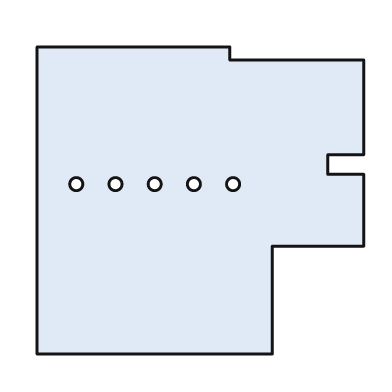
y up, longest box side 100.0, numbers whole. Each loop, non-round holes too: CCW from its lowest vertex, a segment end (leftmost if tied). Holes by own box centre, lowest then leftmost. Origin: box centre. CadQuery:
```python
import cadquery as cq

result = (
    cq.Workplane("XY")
    .moveTo(-50.0, -47.0)
    .lineTo(22.0, -47.0)
    .lineTo(22.0, -14.0)
    .lineTo(50.0, -14.0)
    .lineTo(50.0, 8.0)
    .lineTo(39.0, 8.0)
    .lineTo(39.0, 14.0)
    .lineTo(50.0, 14.0)
    .lineTo(50.0, 43.0)
    .lineTo(9.0, 43.0)
    .lineTo(9.0, 47.0)
    .lineTo(-50.0, 47.0)
    .close()
    .moveTo(-38.0, 5.0)
    .circle(2.0)
    .moveTo(-26.0, 5.0)
    .circle(2.0)
    .moveTo(-14.0, 5.0)
    .circle(2.0)
    .moveTo(-2.0, 5.0)
    .circle(2.0)
    .moveTo(10.0, 5.0)
    .circle(2.0)
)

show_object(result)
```